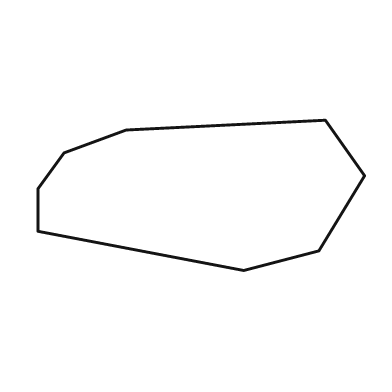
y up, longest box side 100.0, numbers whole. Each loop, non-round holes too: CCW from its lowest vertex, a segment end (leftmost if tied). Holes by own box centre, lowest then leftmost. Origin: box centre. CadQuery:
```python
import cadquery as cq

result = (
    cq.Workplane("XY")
    .moveTo(13.0, -23.0)
    .lineTo(36.0, -17.0)
    .lineTo(50.0, 6.0)
    .lineTo(38.0, 23.0)
    .lineTo(-23.0, 20.0)
    .lineTo(-42.0, 13.0)
    .lineTo(-50.0, 2.0)
    .lineTo(-50.0, -11.0)
    .close()
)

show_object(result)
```